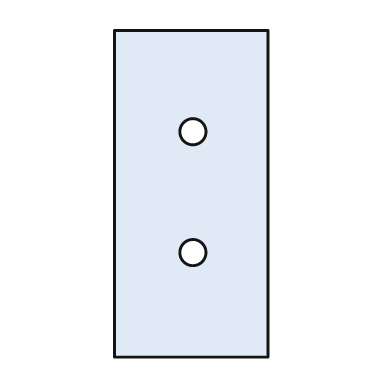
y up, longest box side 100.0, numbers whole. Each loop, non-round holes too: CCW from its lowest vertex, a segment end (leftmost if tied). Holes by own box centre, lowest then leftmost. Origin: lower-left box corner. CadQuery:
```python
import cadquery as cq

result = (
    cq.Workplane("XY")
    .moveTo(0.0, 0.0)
    .lineTo(47.0, 0.0)
    .lineTo(47.0, 100.0)
    .lineTo(0.0, 100.0)
    .close()
    .moveTo(24.0, 32.0)
    .circle(4.0)
    .moveTo(24.0, 69.0)
    .circle(4.0)
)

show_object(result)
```